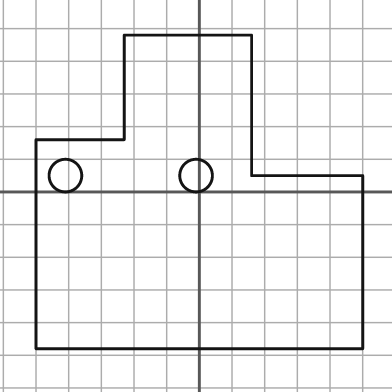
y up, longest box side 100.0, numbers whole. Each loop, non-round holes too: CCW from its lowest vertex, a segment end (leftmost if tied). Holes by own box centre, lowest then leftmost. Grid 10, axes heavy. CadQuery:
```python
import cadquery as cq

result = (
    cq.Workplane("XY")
    .moveTo(-50.0, -48.0)
    .lineTo(50.0, -48.0)
    .lineTo(50.0, 5.0)
    .lineTo(16.0, 5.0)
    .lineTo(16.0, 48.0)
    .lineTo(-23.0, 48.0)
    .lineTo(-23.0, 16.0)
    .lineTo(-50.0, 16.0)
    .close()
    .moveTo(-41.0, 5.0)
    .circle(5.0)
    .moveTo(-1.0, 5.0)
    .circle(5.0)
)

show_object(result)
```